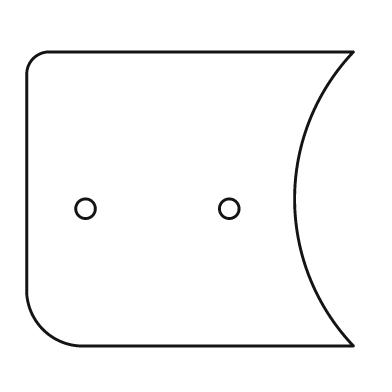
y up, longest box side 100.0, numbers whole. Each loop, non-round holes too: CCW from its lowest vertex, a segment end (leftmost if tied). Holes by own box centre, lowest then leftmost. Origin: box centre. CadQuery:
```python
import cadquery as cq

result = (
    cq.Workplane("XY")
    .moveTo(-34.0, -45.0)
    .lineTo(50.0, -45.0)
    .threePointArc((32.0, 0.0), (50.0, 45.0))
    .lineTo(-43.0, 45.0)
    .threePointArc((-48.0, 43.0), (-50.0, 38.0))
    .lineTo(-50.0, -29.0)
    .threePointArc((-45.0, -40.0), (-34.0, -45.0))
    .close()
    .moveTo(-32.0, -3.0)
    .circle(3.0)
    .moveTo(12.0, -3.0)
    .circle(3.0)
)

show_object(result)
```